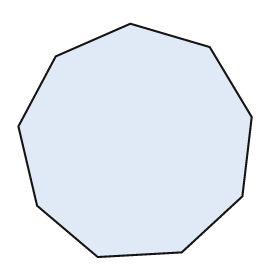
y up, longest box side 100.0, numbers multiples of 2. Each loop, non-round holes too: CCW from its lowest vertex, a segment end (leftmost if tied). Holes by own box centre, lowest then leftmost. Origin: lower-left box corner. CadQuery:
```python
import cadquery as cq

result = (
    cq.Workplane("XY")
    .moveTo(34.0, 0.0)
    .lineTo(70.0, 2.0)
    .lineTo(96.0, 26.0)
    .lineTo(100.0, 60.0)
    .lineTo(82.0, 90.0)
    .lineTo(48.0, 100.0)
    .lineTo(16.0, 86.0)
    .lineTo(0.0, 56.0)
    .lineTo(8.0, 22.0)
    .close()
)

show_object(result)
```